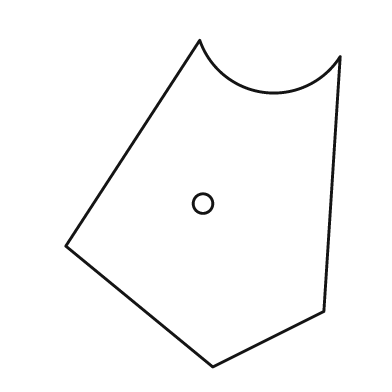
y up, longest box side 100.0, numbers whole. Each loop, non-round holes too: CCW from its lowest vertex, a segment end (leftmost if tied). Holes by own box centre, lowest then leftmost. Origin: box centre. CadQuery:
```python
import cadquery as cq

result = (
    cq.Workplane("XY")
    .moveTo(3.0, -50.0)
    .lineTo(37.0, -33.0)
    .lineTo(42.0, 45.0)
    .threePointArc((19.0, 34.0), (-1.0, 50.0))
    .lineTo(-42.0, -13.0)
    .close()
    .moveTo(0.0, 0.0)
    .circle(3.0)
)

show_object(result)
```